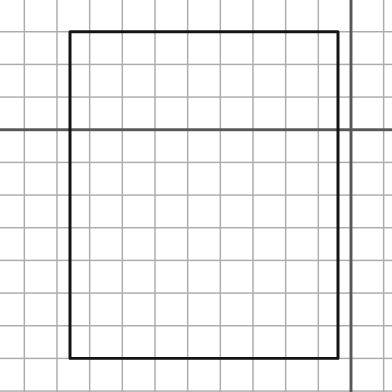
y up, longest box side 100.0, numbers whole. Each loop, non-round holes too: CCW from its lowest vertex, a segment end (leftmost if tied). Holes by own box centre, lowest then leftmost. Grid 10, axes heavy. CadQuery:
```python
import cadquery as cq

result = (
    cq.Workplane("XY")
    .moveTo(-86.0, -70.0)
    .lineTo(-4.0, -70.0)
    .lineTo(-4.0, 30.0)
    .lineTo(-86.0, 30.0)
    .close()
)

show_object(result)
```